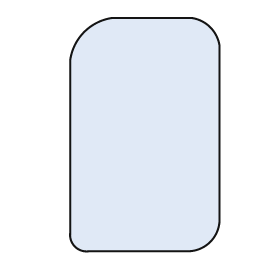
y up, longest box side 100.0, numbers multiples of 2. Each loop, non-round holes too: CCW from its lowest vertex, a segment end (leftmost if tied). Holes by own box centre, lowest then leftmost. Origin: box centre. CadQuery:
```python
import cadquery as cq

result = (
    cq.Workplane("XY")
    .moveTo(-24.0, -50.0)
    .lineTo(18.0, -50.0)
    .threePointArc((28.0, -46.0), (32.0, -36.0))
    .lineTo(32.0, 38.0)
    .threePointArc((28.0, 46.0), (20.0, 50.0))
    .lineTo(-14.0, 50.0)
    .threePointArc((-26.0, 44.0), (-32.0, 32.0))
    .lineTo(-32.0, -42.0)
    .threePointArc((-30.0, -48.0), (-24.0, -50.0))
    .close()
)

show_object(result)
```